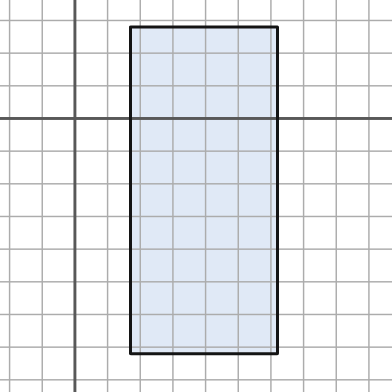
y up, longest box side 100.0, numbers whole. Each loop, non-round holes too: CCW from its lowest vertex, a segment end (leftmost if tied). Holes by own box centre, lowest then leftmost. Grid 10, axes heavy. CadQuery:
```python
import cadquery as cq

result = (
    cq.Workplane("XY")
    .moveTo(17.0, -72.0)
    .lineTo(62.0, -72.0)
    .lineTo(62.0, 28.0)
    .lineTo(17.0, 28.0)
    .close()
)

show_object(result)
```